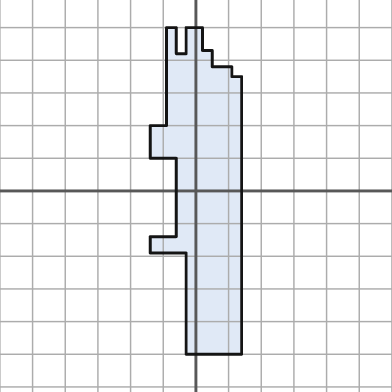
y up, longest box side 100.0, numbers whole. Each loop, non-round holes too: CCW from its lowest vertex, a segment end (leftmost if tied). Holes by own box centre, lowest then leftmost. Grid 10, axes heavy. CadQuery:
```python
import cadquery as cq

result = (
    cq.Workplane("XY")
    .moveTo(-3.0, -50.0)
    .lineTo(14.0, -50.0)
    .lineTo(14.0, 35.0)
    .lineTo(11.0, 35.0)
    .lineTo(11.0, 38.0)
    .lineTo(5.0, 38.0)
    .lineTo(5.0, 43.0)
    .lineTo(2.0, 43.0)
    .lineTo(2.0, 50.0)
    .lineTo(-3.0, 50.0)
    .lineTo(-3.0, 42.0)
    .lineTo(-6.0, 42.0)
    .lineTo(-6.0, 50.0)
    .lineTo(-9.0, 50.0)
    .lineTo(-9.0, 20.0)
    .lineTo(-14.0, 20.0)
    .lineTo(-14.0, 10.0)
    .lineTo(-6.0, 10.0)
    .lineTo(-6.0, -14.0)
    .lineTo(-14.0, -14.0)
    .lineTo(-14.0, -19.0)
    .lineTo(-3.0, -19.0)
    .close()
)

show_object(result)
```